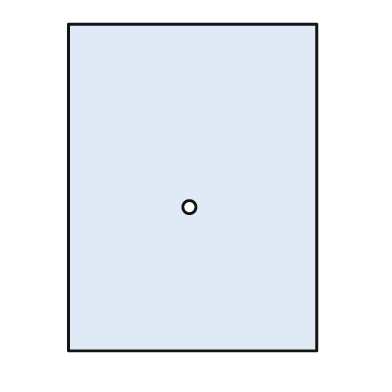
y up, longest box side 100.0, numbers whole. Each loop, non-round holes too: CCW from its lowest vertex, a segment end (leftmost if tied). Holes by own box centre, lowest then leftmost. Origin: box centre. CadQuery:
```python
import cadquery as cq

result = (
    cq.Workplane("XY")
    .moveTo(-38.0, -50.0)
    .lineTo(38.0, -50.0)
    .lineTo(38.0, 50.0)
    .lineTo(-38.0, 50.0)
    .close()
    .moveTo(-1.0, -6.0)
    .circle(2.0)
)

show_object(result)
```